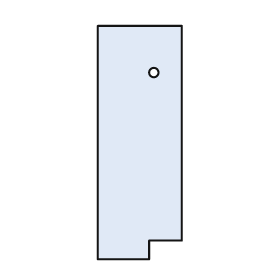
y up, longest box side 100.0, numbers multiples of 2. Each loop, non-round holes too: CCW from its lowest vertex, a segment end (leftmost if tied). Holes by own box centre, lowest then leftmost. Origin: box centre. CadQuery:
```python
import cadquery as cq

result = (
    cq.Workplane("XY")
    .moveTo(-18.0, -50.0)
    .lineTo(4.0, -50.0)
    .lineTo(4.0, -42.0)
    .lineTo(18.0, -42.0)
    .lineTo(18.0, 50.0)
    .lineTo(-18.0, 50.0)
    .close()
    .moveTo(6.0, 30.0)
    .circle(2.0)
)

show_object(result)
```